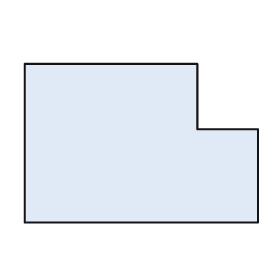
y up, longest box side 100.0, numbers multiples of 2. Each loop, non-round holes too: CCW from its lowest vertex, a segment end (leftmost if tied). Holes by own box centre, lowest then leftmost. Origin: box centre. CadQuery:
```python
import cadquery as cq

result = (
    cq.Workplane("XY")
    .moveTo(-50.0, -34.0)
    .lineTo(50.0, -34.0)
    .lineTo(50.0, 6.0)
    .lineTo(24.0, 6.0)
    .lineTo(24.0, 34.0)
    .lineTo(-50.0, 34.0)
    .close()
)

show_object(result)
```